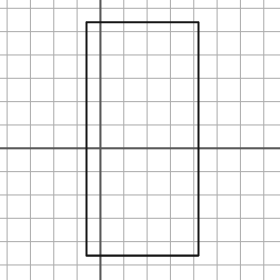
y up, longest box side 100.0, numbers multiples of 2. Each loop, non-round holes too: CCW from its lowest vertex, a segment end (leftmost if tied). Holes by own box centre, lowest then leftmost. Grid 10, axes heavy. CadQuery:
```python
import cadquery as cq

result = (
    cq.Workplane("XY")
    .moveTo(-6.0, -46.0)
    .lineTo(42.0, -46.0)
    .lineTo(42.0, 54.0)
    .lineTo(-6.0, 54.0)
    .close()
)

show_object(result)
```